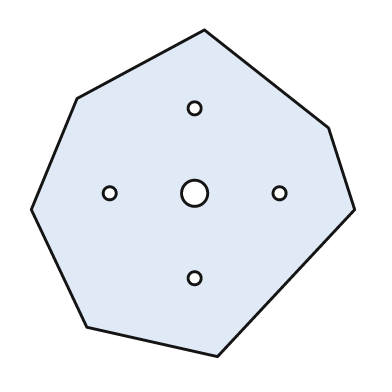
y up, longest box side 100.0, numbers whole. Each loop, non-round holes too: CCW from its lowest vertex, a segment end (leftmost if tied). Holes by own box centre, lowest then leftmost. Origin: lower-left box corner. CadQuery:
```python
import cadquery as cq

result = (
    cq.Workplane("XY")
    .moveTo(57.0, 0.0)
    .lineTo(99.0, 45.0)
    .lineTo(91.0, 70.0)
    .lineTo(53.0, 100.0)
    .lineTo(14.0, 79.0)
    .lineTo(0.0, 45.0)
    .lineTo(17.0, 9.0)
    .close()
    .moveTo(50.0, 24.0)
    .circle(2.0)
    .moveTo(24.0, 50.0)
    .circle(2.0)
    .moveTo(50.0, 50.0)
    .circle(4.0)
    .moveTo(76.0, 50.0)
    .circle(2.0)
    .moveTo(50.0, 76.0)
    .circle(2.0)
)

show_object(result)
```